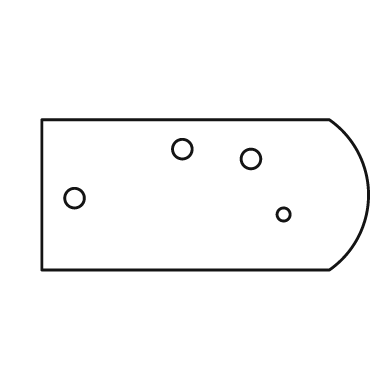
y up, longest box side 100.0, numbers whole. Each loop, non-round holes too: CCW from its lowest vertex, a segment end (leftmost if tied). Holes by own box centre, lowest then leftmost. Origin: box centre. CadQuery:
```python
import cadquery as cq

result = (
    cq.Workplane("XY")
    .moveTo(-50.0, -23.0)
    .lineTo(38.0, -23.0)
    .threePointArc((50.0, 0.0), (38.0, 23.0))
    .lineTo(-50.0, 23.0)
    .close()
    .moveTo(24.0, -6.0)
    .circle(2.0)
    .moveTo(-40.0, -1.0)
    .circle(3.0)
    .moveTo(14.0, 11.0)
    .circle(3.0)
    .moveTo(-7.0, 14.0)
    .circle(3.0)
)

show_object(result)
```